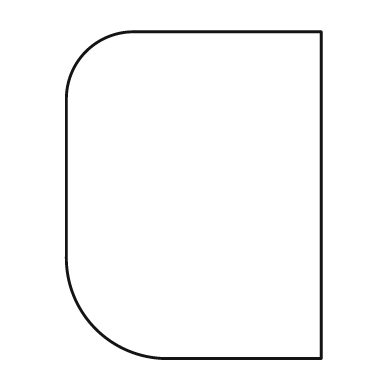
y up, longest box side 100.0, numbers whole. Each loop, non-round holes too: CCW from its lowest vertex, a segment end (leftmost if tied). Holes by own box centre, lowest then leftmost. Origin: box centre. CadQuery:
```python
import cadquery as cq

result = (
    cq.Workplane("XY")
    .moveTo(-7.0, -50.0)
    .lineTo(39.0, -50.0)
    .lineTo(39.0, 50.0)
    .lineTo(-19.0, 50.0)
    .threePointArc((-33.0, 44.0), (-39.0, 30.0))
    .lineTo(-39.0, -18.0)
    .threePointArc((-30.0, -41.0), (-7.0, -50.0))
    .close()
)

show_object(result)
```